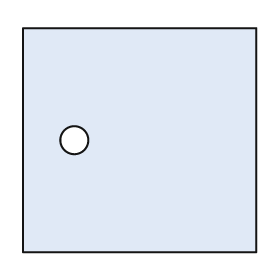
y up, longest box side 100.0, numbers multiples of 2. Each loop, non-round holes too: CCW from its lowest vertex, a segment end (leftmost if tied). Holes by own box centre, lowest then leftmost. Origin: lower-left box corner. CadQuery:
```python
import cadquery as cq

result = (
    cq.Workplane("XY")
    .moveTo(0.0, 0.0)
    .lineTo(100.0, 0.0)
    .lineTo(100.0, 96.0)
    .lineTo(0.0, 96.0)
    .close()
    .moveTo(22.0, 48.0)
    .circle(6.0)
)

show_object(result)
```